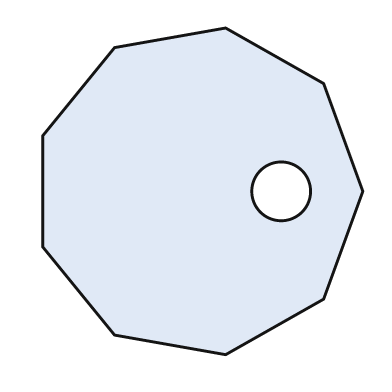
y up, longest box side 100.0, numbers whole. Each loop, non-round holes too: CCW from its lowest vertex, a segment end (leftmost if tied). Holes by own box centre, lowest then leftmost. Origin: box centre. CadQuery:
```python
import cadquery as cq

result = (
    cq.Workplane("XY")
    .moveTo(7.0, -50.0)
    .lineTo(37.0, -33.0)
    .lineTo(49.0, 0.0)
    .lineTo(37.0, 33.0)
    .lineTo(7.0, 50.0)
    .lineTo(-27.0, 44.0)
    .lineTo(-49.0, 17.0)
    .lineTo(-49.0, -17.0)
    .lineTo(-27.0, -44.0)
    .close()
    .moveTo(24.0, 0.0)
    .circle(9.0)
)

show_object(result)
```